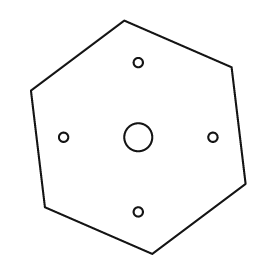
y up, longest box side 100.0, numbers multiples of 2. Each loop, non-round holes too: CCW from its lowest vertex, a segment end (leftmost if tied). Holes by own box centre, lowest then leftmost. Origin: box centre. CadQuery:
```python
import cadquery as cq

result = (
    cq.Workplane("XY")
    .moveTo(6.0, -50.0)
    .lineTo(46.0, -20.0)
    .lineTo(40.0, 30.0)
    .lineTo(-6.0, 50.0)
    .lineTo(-46.0, 20.0)
    .lineTo(-40.0, -30.0)
    .close()
    .moveTo(0.0, -32.0)
    .circle(2.0)
    .moveTo(-32.0, 0.0)
    .circle(2.0)
    .moveTo(0.0, 0.0)
    .circle(6.0)
    .moveTo(32.0, 0.0)
    .circle(2.0)
    .moveTo(0.0, 32.0)
    .circle(2.0)
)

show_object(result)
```